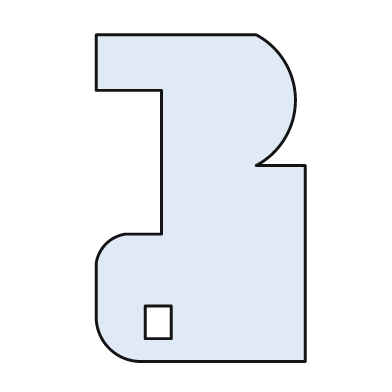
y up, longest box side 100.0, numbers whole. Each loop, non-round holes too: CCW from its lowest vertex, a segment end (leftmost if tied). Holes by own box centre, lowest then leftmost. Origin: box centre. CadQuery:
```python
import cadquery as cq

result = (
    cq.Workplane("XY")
    .moveTo(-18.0, -50.0)
    .lineTo(32.0, -50.0)
    .lineTo(32.0, 10.0)
    .lineTo(17.0, 10.0)
    .threePointArc((29.0, 30.0), (17.0, 50.0))
    .lineTo(-32.0, 50.0)
    .lineTo(-32.0, 33.0)
    .lineTo(-12.0, 33.0)
    .lineTo(-12.0, -11.0)
    .lineTo(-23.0, -11.0)
    .threePointArc((-29.0, -14.0), (-32.0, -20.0))
    .lineTo(-32.0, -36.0)
    .threePointArc((-28.0, -46.0), (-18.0, -50.0))
    .close()
    .moveTo(-17.0, -43.0)
    .lineTo(-9.0, -43.0)
    .lineTo(-9.0, -33.0)
    .lineTo(-17.0, -33.0)
    .close()
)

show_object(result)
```